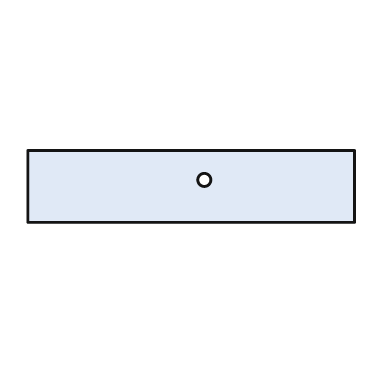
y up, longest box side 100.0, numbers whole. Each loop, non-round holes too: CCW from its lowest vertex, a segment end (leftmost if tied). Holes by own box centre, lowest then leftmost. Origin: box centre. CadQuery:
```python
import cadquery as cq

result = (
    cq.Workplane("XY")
    .moveTo(-50.0, -11.0)
    .lineTo(50.0, -11.0)
    .lineTo(50.0, 11.0)
    .lineTo(-50.0, 11.0)
    .close()
    .moveTo(4.0, 2.0)
    .circle(2.0)
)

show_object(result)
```